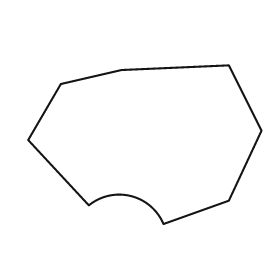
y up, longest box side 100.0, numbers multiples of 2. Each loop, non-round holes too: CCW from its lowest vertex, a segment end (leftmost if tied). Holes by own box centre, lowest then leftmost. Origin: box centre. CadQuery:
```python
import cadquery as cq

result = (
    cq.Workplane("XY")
    .moveTo(8.0, -34.0)
    .lineTo(36.0, -24.0)
    .lineTo(50.0, 6.0)
    .lineTo(36.0, 34.0)
    .lineTo(-10.0, 32.0)
    .lineTo(-36.0, 26.0)
    .lineTo(-50.0, 2.0)
    .lineTo(-24.0, -26.0)
    .threePointArc((-6.0, -22.0), (8.0, -34.0))
    .close()
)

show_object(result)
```